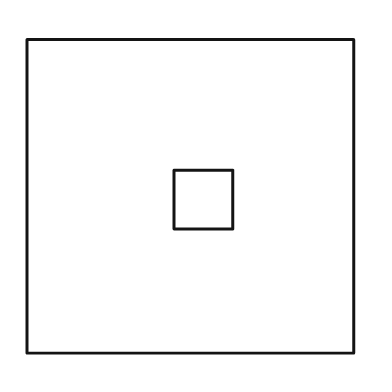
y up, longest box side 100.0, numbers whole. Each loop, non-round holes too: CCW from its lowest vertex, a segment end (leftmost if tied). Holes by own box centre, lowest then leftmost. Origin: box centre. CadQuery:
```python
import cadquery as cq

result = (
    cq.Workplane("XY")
    .moveTo(-50.0, -48.0)
    .lineTo(50.0, -48.0)
    .lineTo(50.0, 48.0)
    .lineTo(-50.0, 48.0)
    .close()
    .moveTo(-5.0, -10.0)
    .lineTo(13.0, -10.0)
    .lineTo(13.0, 8.0)
    .lineTo(-5.0, 8.0)
    .close()
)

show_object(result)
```